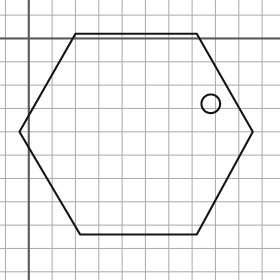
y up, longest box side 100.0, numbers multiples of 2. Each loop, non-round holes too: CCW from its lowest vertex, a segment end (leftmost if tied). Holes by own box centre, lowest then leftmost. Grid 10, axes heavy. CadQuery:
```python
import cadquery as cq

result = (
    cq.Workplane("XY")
    .moveTo(22.0, -84.0)
    .lineTo(72.0, -84.0)
    .lineTo(96.0, -40.0)
    .lineTo(72.0, 2.0)
    .lineTo(20.0, 2.0)
    .lineTo(-4.0, -40.0)
    .close()
    .moveTo(78.0, -28.0)
    .circle(4.0)
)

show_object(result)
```